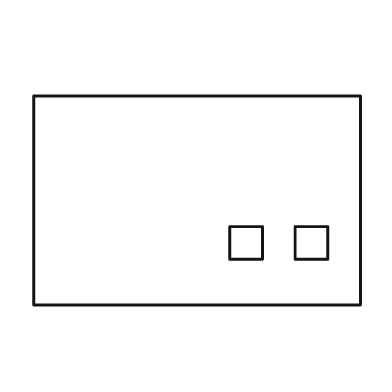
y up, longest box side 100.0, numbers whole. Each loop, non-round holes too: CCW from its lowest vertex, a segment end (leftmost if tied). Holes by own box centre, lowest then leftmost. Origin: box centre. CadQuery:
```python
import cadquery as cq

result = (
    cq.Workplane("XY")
    .moveTo(-50.0, -32.0)
    .lineTo(50.0, -32.0)
    .lineTo(50.0, 32.0)
    .lineTo(-50.0, 32.0)
    .close()
    .moveTo(10.0, -18.0)
    .lineTo(20.0, -18.0)
    .lineTo(20.0, -8.0)
    .lineTo(10.0, -8.0)
    .close()
    .moveTo(30.0, -18.0)
    .lineTo(40.0, -18.0)
    .lineTo(40.0, -8.0)
    .lineTo(30.0, -8.0)
    .close()
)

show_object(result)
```